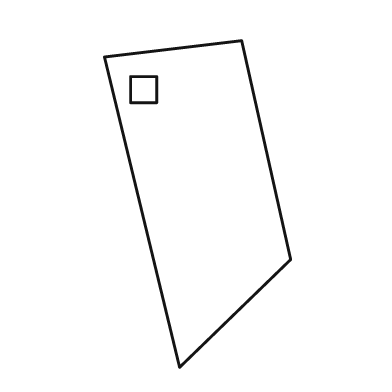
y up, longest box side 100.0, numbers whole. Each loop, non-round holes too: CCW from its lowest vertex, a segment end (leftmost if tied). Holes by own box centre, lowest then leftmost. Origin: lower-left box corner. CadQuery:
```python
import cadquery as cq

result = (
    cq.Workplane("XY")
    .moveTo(23.0, 0.0)
    .lineTo(57.0, 33.0)
    .lineTo(42.0, 100.0)
    .lineTo(0.0, 95.0)
    .close()
    .moveTo(8.0, 81.0)
    .lineTo(16.0, 81.0)
    .lineTo(16.0, 89.0)
    .lineTo(8.0, 89.0)
    .close()
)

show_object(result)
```